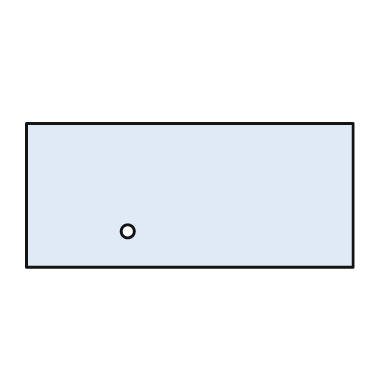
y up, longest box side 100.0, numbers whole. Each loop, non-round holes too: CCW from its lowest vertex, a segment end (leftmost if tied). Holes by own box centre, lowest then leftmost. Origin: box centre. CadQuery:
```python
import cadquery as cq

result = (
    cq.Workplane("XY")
    .moveTo(-50.0, -22.0)
    .lineTo(50.0, -22.0)
    .lineTo(50.0, 22.0)
    .lineTo(-50.0, 22.0)
    .close()
    .moveTo(-19.0, -11.0)
    .circle(2.0)
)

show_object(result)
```